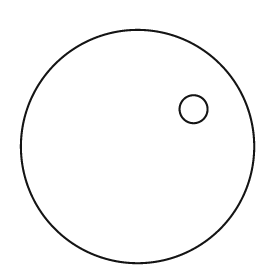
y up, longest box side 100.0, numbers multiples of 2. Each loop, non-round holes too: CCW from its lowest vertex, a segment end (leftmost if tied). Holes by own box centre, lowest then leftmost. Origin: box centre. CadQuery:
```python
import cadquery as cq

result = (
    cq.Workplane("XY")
    .moveTo(0.0, 0.0)
    .circle(50.0)
    .moveTo(24.0, 16.0)
    .circle(6.0)
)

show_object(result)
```